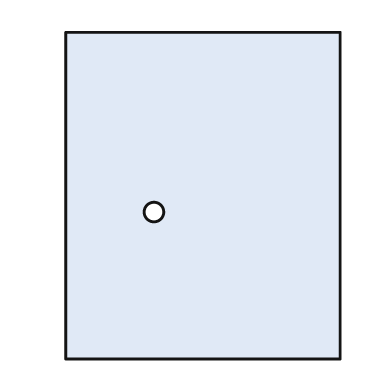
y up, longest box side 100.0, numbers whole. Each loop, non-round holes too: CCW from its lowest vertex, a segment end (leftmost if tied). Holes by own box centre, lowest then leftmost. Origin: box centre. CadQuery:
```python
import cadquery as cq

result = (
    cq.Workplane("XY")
    .moveTo(-42.0, -50.0)
    .lineTo(42.0, -50.0)
    .lineTo(42.0, 50.0)
    .lineTo(-42.0, 50.0)
    .close()
    .moveTo(-15.0, -5.0)
    .circle(3.0)
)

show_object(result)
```